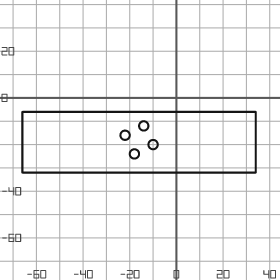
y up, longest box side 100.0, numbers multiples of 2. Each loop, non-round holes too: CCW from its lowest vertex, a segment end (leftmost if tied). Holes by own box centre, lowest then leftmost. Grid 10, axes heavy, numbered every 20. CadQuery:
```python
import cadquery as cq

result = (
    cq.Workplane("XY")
    .moveTo(-66.0, -32.0)
    .lineTo(34.0, -32.0)
    .lineTo(34.0, -6.0)
    .lineTo(-66.0, -6.0)
    .close()
    .moveTo(-18.0, -24.0)
    .circle(2.0)
    .moveTo(-10.0, -20.0)
    .circle(2.0)
    .moveTo(-22.0, -16.0)
    .circle(2.0)
    .moveTo(-14.0, -12.0)
    .circle(2.0)
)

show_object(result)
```